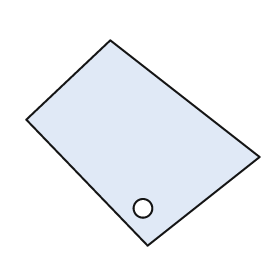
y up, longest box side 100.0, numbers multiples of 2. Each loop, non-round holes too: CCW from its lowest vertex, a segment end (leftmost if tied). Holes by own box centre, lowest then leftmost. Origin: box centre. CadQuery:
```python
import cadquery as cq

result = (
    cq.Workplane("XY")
    .moveTo(2.0, -44.0)
    .lineTo(50.0, -6.0)
    .lineTo(-14.0, 44.0)
    .lineTo(-50.0, 10.0)
    .close()
    .moveTo(0.0, -28.0)
    .circle(4.0)
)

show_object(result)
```